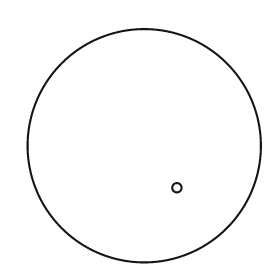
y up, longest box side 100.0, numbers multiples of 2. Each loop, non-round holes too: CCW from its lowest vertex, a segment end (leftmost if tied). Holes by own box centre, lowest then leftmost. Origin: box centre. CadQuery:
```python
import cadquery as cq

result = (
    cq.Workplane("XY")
    .moveTo(0.0, 0.0)
    .circle(50.0)
    .moveTo(14.0, -18.0)
    .circle(2.0)
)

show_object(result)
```